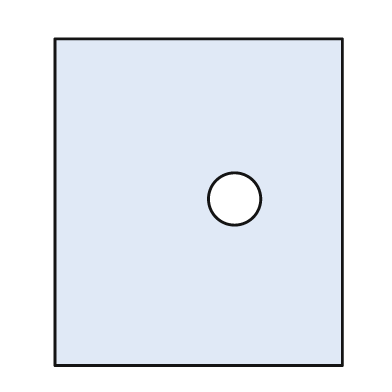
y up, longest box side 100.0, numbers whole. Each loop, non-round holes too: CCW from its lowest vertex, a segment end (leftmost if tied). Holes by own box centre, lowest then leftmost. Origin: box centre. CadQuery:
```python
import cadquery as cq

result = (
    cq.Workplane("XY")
    .moveTo(-44.0, -50.0)
    .lineTo(44.0, -50.0)
    .lineTo(44.0, 50.0)
    .lineTo(-44.0, 50.0)
    .close()
    .moveTo(11.0, 1.0)
    .circle(8.0)
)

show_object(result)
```